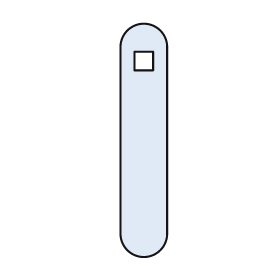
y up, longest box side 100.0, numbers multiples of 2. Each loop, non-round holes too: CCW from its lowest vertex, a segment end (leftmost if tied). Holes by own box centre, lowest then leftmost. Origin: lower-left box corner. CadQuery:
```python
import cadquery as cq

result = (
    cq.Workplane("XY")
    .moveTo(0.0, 10.0)
    .threePointArc((10.0, 0.0), (20.0, 10.0))
    .lineTo(20.0, 90.0)
    .threePointArc((10.0, 100.0), (0.0, 90.0))
    .close()
    .moveTo(6.0, 80.0)
    .lineTo(14.0, 80.0)
    .lineTo(14.0, 88.0)
    .lineTo(6.0, 88.0)
    .close()
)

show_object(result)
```